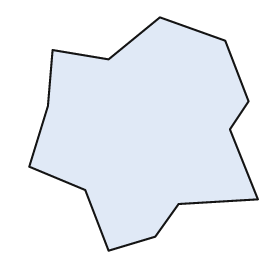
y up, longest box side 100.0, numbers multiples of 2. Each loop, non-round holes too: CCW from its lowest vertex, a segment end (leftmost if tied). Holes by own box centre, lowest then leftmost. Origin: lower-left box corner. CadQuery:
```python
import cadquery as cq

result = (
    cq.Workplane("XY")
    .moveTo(34.0, 0.0)
    .lineTo(54.0, 6.0)
    .lineTo(64.0, 20.0)
    .lineTo(98.0, 22.0)
    .lineTo(86.0, 52.0)
    .lineTo(94.0, 64.0)
    .lineTo(84.0, 90.0)
    .lineTo(56.0, 100.0)
    .lineTo(34.0, 82.0)
    .lineTo(10.0, 86.0)
    .lineTo(8.0, 62.0)
    .lineTo(0.0, 36.0)
    .lineTo(24.0, 26.0)
    .close()
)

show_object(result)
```